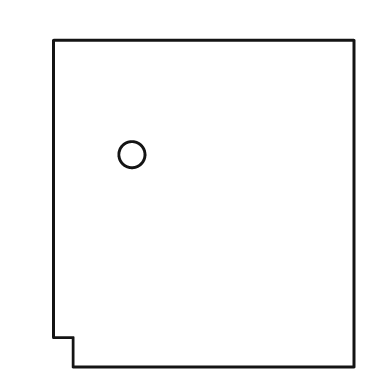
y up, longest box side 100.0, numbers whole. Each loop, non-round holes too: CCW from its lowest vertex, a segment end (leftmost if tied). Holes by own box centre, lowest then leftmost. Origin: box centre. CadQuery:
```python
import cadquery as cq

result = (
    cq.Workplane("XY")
    .moveTo(-40.0, -50.0)
    .lineTo(46.0, -50.0)
    .lineTo(46.0, 50.0)
    .lineTo(-46.0, 50.0)
    .lineTo(-46.0, -41.0)
    .lineTo(-40.0, -41.0)
    .close()
    .moveTo(-22.0, 15.0)
    .circle(4.0)
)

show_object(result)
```